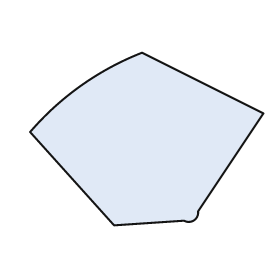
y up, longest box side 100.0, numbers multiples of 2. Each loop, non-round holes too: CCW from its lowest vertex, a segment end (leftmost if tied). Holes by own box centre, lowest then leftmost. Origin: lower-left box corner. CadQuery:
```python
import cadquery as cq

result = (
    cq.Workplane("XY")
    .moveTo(36.0, 0.0)
    .lineTo(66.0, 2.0)
    .threePointArc((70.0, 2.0), (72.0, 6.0))
    .lineTo(100.0, 48.0)
    .lineTo(48.0, 74.0)
    .threePointArc((22.0, 60.0), (0.0, 40.0))
    .close()
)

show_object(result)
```